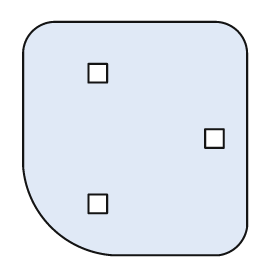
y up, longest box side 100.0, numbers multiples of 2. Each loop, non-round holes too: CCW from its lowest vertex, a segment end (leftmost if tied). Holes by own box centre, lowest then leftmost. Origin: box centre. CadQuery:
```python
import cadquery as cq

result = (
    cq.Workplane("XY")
    .moveTo(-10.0, -50.0)
    .lineTo(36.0, -50.0)
    .threePointArc((44.0, -46.0), (48.0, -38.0))
    .lineTo(48.0, 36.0)
    .threePointArc((44.0, 46.0), (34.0, 50.0))
    .lineTo(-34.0, 50.0)
    .threePointArc((-44.0, 46.0), (-48.0, 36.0))
    .lineTo(-48.0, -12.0)
    .threePointArc((-36.0, -38.0), (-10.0, -50.0))
    .close()
    .moveTo(-20.0, -32.0)
    .lineTo(-12.0, -32.0)
    .lineTo(-12.0, -24.0)
    .lineTo(-20.0, -24.0)
    .close()
    .moveTo(30.0, -4.0)
    .lineTo(38.0, -4.0)
    .lineTo(38.0, 4.0)
    .lineTo(30.0, 4.0)
    .close()
    .moveTo(-20.0, 24.0)
    .lineTo(-12.0, 24.0)
    .lineTo(-12.0, 32.0)
    .lineTo(-20.0, 32.0)
    .close()
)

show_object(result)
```